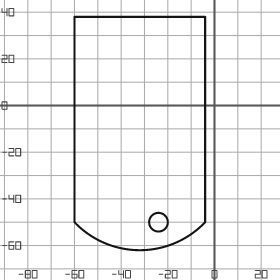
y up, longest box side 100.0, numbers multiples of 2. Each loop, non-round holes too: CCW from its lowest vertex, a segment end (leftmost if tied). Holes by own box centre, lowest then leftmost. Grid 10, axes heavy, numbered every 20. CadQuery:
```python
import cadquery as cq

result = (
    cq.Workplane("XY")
    .moveTo(-60.0, -50.0)
    .threePointArc((-32.0, -62.0), (-4.0, -50.0))
    .lineTo(-4.0, 38.0)
    .lineTo(-60.0, 38.0)
    .close()
    .moveTo(-24.0, -50.0)
    .circle(4.0)
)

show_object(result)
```